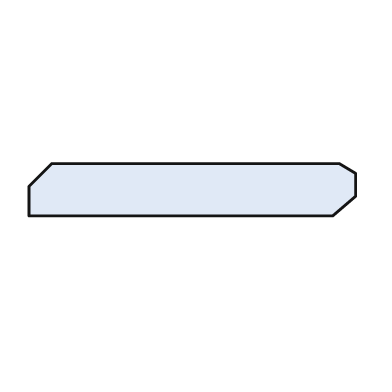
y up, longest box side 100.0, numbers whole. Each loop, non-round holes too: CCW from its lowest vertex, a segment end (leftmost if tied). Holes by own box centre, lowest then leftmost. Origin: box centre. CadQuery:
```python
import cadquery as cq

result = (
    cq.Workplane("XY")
    .moveTo(-50.0, -8.0)
    .lineTo(43.0, -8.0)
    .lineTo(50.0, -2.0)
    .lineTo(50.0, 5.0)
    .lineTo(45.0, 8.0)
    .lineTo(-43.0, 8.0)
    .lineTo(-50.0, 1.0)
    .close()
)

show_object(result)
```